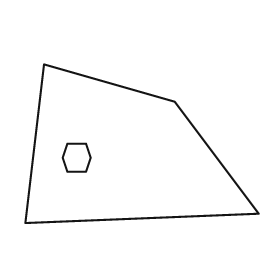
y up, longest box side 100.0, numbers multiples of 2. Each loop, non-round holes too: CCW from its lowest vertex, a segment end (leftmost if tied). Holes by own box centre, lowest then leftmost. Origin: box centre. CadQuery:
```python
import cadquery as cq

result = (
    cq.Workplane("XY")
    .moveTo(-50.0, -34.0)
    .lineTo(50.0, -30.0)
    .lineTo(14.0, 18.0)
    .lineTo(-42.0, 34.0)
    .close()
    .moveTo(-32.0, -12.0)
    .lineTo(-24.0, -12.0)
    .lineTo(-22.0, -6.0)
    .lineTo(-24.0, 0.0)
    .lineTo(-32.0, 0.0)
    .lineTo(-34.0, -6.0)
    .close()
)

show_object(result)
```